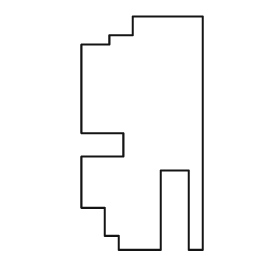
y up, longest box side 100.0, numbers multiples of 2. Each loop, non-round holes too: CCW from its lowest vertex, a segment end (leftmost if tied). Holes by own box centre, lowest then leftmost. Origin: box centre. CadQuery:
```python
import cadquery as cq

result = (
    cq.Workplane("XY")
    .moveTo(-10.0, -50.0)
    .lineTo(8.0, -50.0)
    .lineTo(8.0, -16.0)
    .lineTo(20.0, -16.0)
    .lineTo(20.0, -50.0)
    .lineTo(26.0, -50.0)
    .lineTo(26.0, 50.0)
    .lineTo(-4.0, 50.0)
    .lineTo(-4.0, 42.0)
    .lineTo(-14.0, 42.0)
    .lineTo(-14.0, 38.0)
    .lineTo(-26.0, 38.0)
    .lineTo(-26.0, 0.0)
    .lineTo(-8.0, 0.0)
    .lineTo(-8.0, -10.0)
    .lineTo(-26.0, -10.0)
    .lineTo(-26.0, -32.0)
    .lineTo(-16.0, -32.0)
    .lineTo(-16.0, -44.0)
    .lineTo(-10.0, -44.0)
    .close()
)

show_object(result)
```